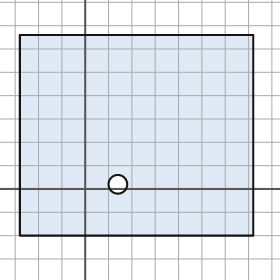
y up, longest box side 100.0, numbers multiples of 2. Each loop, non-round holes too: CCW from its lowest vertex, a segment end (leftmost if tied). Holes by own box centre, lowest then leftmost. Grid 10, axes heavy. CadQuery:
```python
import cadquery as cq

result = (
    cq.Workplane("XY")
    .moveTo(-28.0, -20.0)
    .lineTo(72.0, -20.0)
    .lineTo(72.0, 66.0)
    .lineTo(-28.0, 66.0)
    .close()
    .moveTo(14.0, 2.0)
    .circle(4.0)
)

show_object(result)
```